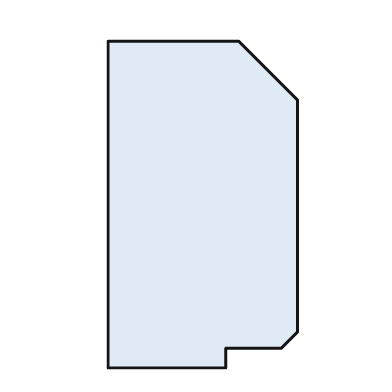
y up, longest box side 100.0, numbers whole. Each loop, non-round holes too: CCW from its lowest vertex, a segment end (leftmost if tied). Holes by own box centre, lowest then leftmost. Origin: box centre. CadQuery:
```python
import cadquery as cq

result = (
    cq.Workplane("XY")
    .moveTo(-29.0, -50.0)
    .lineTo(7.0, -50.0)
    .lineTo(7.0, -44.0)
    .lineTo(24.0, -44.0)
    .lineTo(29.0, -39.0)
    .lineTo(29.0, 32.0)
    .lineTo(11.0, 50.0)
    .lineTo(-29.0, 50.0)
    .close()
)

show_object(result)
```